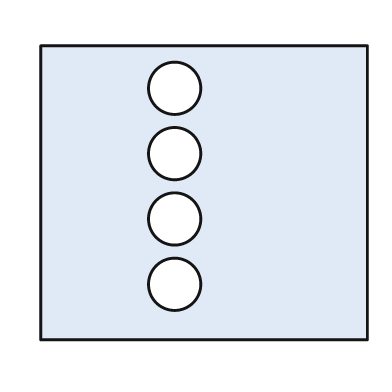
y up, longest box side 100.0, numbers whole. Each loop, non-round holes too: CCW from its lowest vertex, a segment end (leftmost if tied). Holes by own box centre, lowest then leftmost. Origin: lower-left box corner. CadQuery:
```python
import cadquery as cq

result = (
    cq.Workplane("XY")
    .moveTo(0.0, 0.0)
    .lineTo(100.0, 0.0)
    .lineTo(100.0, 90.0)
    .lineTo(0.0, 90.0)
    .close()
    .moveTo(41.0, 17.0)
    .circle(8.0)
    .moveTo(41.0, 37.0)
    .circle(8.0)
    .moveTo(41.0, 57.0)
    .circle(8.0)
    .moveTo(41.0, 77.0)
    .circle(8.0)
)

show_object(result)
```